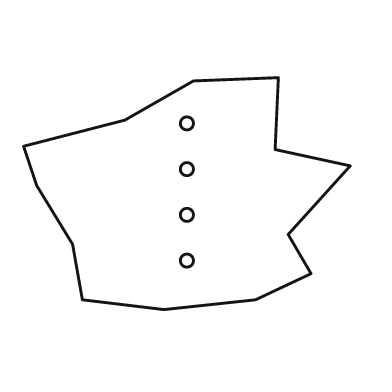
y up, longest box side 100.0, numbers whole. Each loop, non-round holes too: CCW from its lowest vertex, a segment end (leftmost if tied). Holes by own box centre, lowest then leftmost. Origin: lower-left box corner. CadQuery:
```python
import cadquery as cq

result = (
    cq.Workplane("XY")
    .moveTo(43.0, 0.0)
    .lineTo(71.0, 3.0)
    .lineTo(88.0, 11.0)
    .lineTo(81.0, 23.0)
    .lineTo(100.0, 44.0)
    .lineTo(77.0, 49.0)
    .lineTo(78.0, 71.0)
    .lineTo(52.0, 70.0)
    .lineTo(31.0, 58.0)
    .lineTo(0.0, 50.0)
    .lineTo(4.0, 38.0)
    .lineTo(15.0, 20.0)
    .lineTo(18.0, 3.0)
    .close()
    .moveTo(50.0, 15.0)
    .circle(2.0)
    .moveTo(50.0, 29.0)
    .circle(2.0)
    .moveTo(50.0, 43.0)
    .circle(2.0)
    .moveTo(50.0, 57.0)
    .circle(2.0)
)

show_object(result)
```